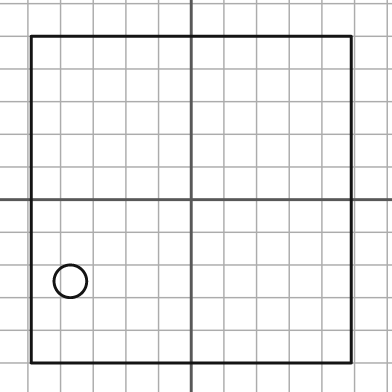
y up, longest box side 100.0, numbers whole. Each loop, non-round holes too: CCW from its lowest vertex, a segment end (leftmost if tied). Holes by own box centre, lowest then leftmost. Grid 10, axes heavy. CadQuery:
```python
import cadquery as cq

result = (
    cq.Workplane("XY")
    .moveTo(-49.0, -50.0)
    .lineTo(49.0, -50.0)
    .lineTo(49.0, 50.0)
    .lineTo(-49.0, 50.0)
    .close()
    .moveTo(-37.0, -25.0)
    .circle(5.0)
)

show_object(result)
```